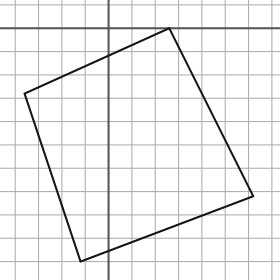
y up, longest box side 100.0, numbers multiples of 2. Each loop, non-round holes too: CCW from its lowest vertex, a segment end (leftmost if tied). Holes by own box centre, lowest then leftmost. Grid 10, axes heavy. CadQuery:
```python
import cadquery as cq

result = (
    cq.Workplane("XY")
    .moveTo(-12.0, -100.0)
    .lineTo(62.0, -72.0)
    .lineTo(26.0, 0.0)
    .lineTo(-36.0, -28.0)
    .close()
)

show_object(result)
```